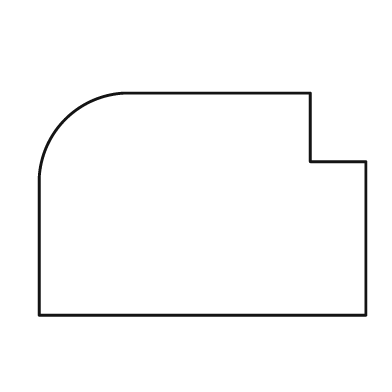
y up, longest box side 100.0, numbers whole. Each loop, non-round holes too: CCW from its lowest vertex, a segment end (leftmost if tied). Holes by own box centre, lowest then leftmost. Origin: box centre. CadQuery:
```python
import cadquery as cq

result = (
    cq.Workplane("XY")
    .moveTo(-50.0, -34.0)
    .lineTo(50.0, -34.0)
    .lineTo(50.0, 13.0)
    .lineTo(33.0, 13.0)
    .lineTo(33.0, 34.0)
    .lineTo(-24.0, 34.0)
    .threePointArc((-42.0, 26.0), (-50.0, 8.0))
    .close()
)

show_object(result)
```